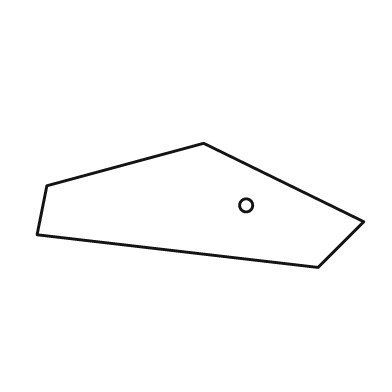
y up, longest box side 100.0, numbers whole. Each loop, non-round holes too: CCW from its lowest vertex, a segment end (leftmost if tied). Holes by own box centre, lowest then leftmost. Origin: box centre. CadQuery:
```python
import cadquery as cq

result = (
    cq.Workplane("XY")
    .moveTo(36.0, -19.0)
    .lineTo(50.0, -5.0)
    .lineTo(1.0, 19.0)
    .lineTo(-47.0, 6.0)
    .lineTo(-50.0, -9.0)
    .close()
    .moveTo(14.0, 0.0)
    .circle(2.0)
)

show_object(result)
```